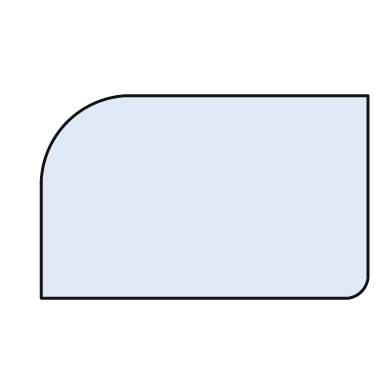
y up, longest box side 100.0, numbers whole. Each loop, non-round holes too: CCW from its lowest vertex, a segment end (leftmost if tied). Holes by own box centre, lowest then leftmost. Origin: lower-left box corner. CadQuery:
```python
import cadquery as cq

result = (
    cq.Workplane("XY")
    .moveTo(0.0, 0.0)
    .lineTo(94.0, 0.0)
    .threePointArc((98.0, 2.0), (100.0, 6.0))
    .lineTo(100.0, 62.0)
    .lineTo(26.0, 62.0)
    .threePointArc((8.0, 54.0), (0.0, 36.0))
    .close()
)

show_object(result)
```